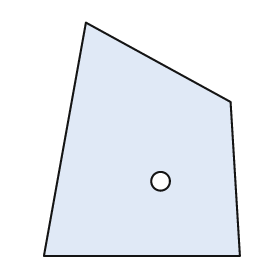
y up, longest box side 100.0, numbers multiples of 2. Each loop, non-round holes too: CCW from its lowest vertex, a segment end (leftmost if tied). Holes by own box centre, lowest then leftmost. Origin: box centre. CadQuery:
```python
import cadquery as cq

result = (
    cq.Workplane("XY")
    .moveTo(-42.0, -50.0)
    .lineTo(42.0, -50.0)
    .lineTo(38.0, 16.0)
    .lineTo(-24.0, 50.0)
    .close()
    .moveTo(8.0, -18.0)
    .circle(4.0)
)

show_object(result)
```